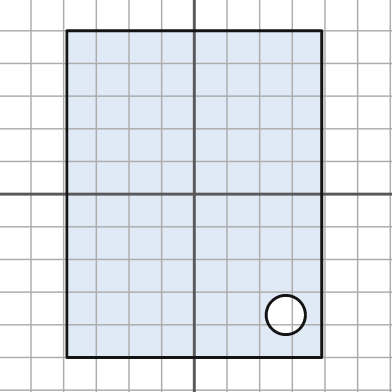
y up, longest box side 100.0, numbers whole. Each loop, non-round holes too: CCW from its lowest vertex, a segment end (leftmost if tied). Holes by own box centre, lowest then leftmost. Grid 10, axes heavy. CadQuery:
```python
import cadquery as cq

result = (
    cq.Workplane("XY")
    .moveTo(-39.0, -50.0)
    .lineTo(39.0, -50.0)
    .lineTo(39.0, 50.0)
    .lineTo(-39.0, 50.0)
    .close()
    .moveTo(28.0, -37.0)
    .circle(6.0)
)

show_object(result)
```